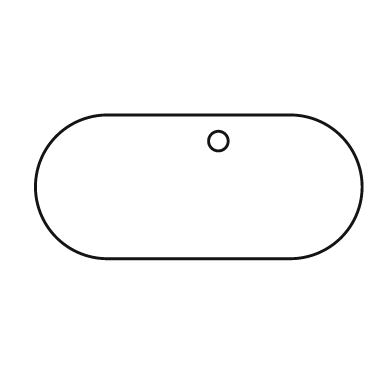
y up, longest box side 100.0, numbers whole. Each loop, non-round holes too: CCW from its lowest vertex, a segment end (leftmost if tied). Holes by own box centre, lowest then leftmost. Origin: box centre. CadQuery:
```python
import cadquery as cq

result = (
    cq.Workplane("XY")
    .moveTo(-28.0, -22.0)
    .lineTo(28.0, -22.0)
    .threePointArc((50.0, 0.0), (28.0, 22.0))
    .lineTo(-28.0, 22.0)
    .threePointArc((-50.0, 0.0), (-28.0, -22.0))
    .close()
    .moveTo(6.0, 14.0)
    .circle(3.0)
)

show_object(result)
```